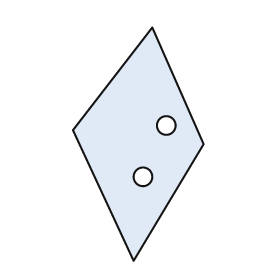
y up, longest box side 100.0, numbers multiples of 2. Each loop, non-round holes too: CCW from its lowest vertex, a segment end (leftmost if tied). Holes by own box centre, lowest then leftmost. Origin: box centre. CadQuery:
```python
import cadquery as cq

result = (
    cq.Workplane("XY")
    .moveTo(-2.0, -50.0)
    .lineTo(28.0, 0.0)
    .lineTo(6.0, 50.0)
    .lineTo(-28.0, 6.0)
    .close()
    .moveTo(2.0, -14.0)
    .circle(4.0)
    .moveTo(12.0, 8.0)
    .circle(4.0)
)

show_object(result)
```